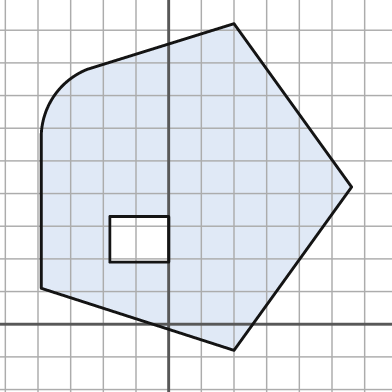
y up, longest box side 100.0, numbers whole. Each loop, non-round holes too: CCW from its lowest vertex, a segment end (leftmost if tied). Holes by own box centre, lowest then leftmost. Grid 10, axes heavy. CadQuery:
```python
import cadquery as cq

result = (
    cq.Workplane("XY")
    .moveTo(20.0, -8.0)
    .lineTo(56.0, 42.0)
    .lineTo(20.0, 92.0)
    .lineTo(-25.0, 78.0)
    .threePointArc((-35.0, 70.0), (-39.0, 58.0))
    .lineTo(-39.0, 11.0)
    .close()
    .moveTo(-18.0, 19.0)
    .lineTo(0.0, 19.0)
    .lineTo(0.0, 33.0)
    .lineTo(-18.0, 33.0)
    .close()
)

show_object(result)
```